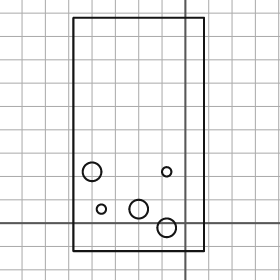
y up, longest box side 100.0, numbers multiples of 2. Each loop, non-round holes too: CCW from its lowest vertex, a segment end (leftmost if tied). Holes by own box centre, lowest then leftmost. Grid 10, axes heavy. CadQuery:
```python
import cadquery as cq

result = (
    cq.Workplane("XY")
    .moveTo(-48.0, -12.0)
    .lineTo(8.0, -12.0)
    .lineTo(8.0, 88.0)
    .lineTo(-48.0, 88.0)
    .close()
    .moveTo(-8.0, -2.0)
    .circle(4.0)
    .moveTo(-36.0, 6.0)
    .circle(2.0)
    .moveTo(-20.0, 6.0)
    .circle(4.0)
    .moveTo(-40.0, 22.0)
    .circle(4.0)
    .moveTo(-8.0, 22.0)
    .circle(2.0)
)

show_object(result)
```